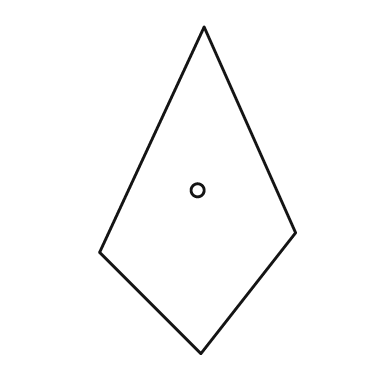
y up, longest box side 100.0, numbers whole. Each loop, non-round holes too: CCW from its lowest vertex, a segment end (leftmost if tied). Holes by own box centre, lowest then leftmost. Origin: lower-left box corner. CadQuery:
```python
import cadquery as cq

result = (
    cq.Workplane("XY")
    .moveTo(31.0, 0.0)
    .lineTo(60.0, 37.0)
    .lineTo(32.0, 100.0)
    .lineTo(0.0, 31.0)
    .close()
    .moveTo(30.0, 50.0)
    .circle(2.0)
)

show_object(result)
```